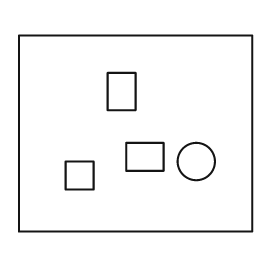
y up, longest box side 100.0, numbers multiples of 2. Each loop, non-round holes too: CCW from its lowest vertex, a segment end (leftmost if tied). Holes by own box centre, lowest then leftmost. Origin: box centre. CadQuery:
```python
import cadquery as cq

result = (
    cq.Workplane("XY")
    .moveTo(-50.0, -42.0)
    .lineTo(50.0, -42.0)
    .lineTo(50.0, 42.0)
    .lineTo(-50.0, 42.0)
    .close()
    .moveTo(-30.0, -24.0)
    .lineTo(-18.0, -24.0)
    .lineTo(-18.0, -12.0)
    .lineTo(-30.0, -12.0)
    .close()
    .moveTo(26.0, -12.0)
    .circle(8.0)
    .moveTo(-4.0, -16.0)
    .lineTo(12.0, -16.0)
    .lineTo(12.0, -4.0)
    .lineTo(-4.0, -4.0)
    .close()
    .moveTo(-12.0, 10.0)
    .lineTo(0.0, 10.0)
    .lineTo(0.0, 26.0)
    .lineTo(-12.0, 26.0)
    .close()
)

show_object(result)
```